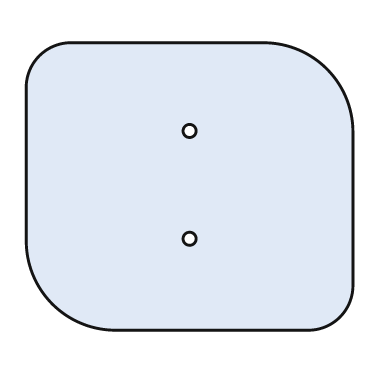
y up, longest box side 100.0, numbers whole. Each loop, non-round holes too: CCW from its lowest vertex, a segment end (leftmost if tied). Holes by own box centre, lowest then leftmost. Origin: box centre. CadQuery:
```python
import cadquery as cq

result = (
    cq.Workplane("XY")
    .moveTo(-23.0, -44.0)
    .lineTo(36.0, -44.0)
    .threePointArc((46.0, -40.0), (50.0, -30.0))
    .lineTo(50.0, 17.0)
    .threePointArc((42.0, 36.0), (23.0, 44.0))
    .lineTo(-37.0, 44.0)
    .threePointArc((-46.0, 40.0), (-50.0, 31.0))
    .lineTo(-50.0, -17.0)
    .threePointArc((-42.0, -36.0), (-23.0, -44.0))
    .close()
    .moveTo(0.0, -16.0)
    .circle(2.0)
    .moveTo(0.0, 17.0)
    .circle(2.0)
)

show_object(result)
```